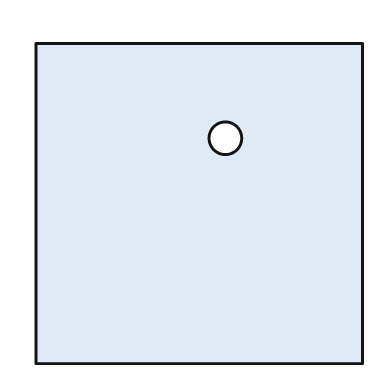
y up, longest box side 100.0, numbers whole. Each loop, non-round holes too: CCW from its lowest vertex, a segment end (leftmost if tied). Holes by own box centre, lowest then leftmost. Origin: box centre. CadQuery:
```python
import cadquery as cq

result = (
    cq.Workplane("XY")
    .moveTo(-50.0, -49.0)
    .lineTo(50.0, -49.0)
    .lineTo(50.0, 49.0)
    .lineTo(-50.0, 49.0)
    .close()
    .moveTo(8.0, 20.0)
    .circle(5.0)
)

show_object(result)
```